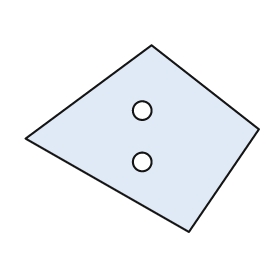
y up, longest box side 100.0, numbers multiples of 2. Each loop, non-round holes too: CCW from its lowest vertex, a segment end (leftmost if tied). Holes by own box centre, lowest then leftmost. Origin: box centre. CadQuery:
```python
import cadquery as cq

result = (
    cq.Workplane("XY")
    .moveTo(20.0, -40.0)
    .lineTo(50.0, 4.0)
    .lineTo(4.0, 40.0)
    .lineTo(-50.0, 0.0)
    .close()
    .moveTo(0.0, -10.0)
    .circle(4.0)
    .moveTo(0.0, 12.0)
    .circle(4.0)
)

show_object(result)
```